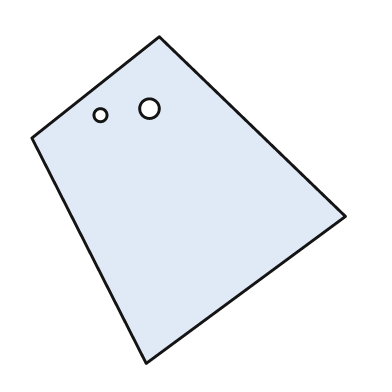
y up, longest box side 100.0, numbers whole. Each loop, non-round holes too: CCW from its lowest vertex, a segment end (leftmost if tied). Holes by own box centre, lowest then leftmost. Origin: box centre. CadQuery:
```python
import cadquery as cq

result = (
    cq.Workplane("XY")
    .moveTo(-13.0, -50.0)
    .lineTo(48.0, -5.0)
    .lineTo(-9.0, 50.0)
    .lineTo(-48.0, 19.0)
    .close()
    .moveTo(-27.0, 26.0)
    .circle(2.0)
    .moveTo(-12.0, 28.0)
    .circle(3.0)
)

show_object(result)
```